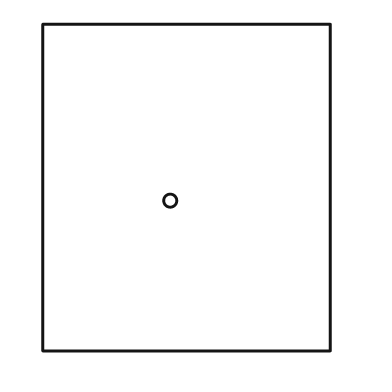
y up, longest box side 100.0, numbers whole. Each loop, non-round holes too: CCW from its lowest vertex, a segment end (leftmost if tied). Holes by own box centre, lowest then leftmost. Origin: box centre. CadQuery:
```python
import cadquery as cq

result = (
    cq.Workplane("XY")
    .moveTo(-44.0, -50.0)
    .lineTo(44.0, -50.0)
    .lineTo(44.0, 50.0)
    .lineTo(-44.0, 50.0)
    .close()
    .moveTo(-5.0, -4.0)
    .circle(2.0)
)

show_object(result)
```